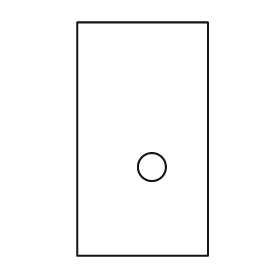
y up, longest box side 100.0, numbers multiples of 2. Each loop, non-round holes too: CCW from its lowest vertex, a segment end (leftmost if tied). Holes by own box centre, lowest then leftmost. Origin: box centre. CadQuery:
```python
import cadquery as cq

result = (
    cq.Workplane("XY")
    .moveTo(-28.0, -50.0)
    .lineTo(28.0, -50.0)
    .lineTo(28.0, 50.0)
    .lineTo(-28.0, 50.0)
    .close()
    .moveTo(4.0, -12.0)
    .circle(6.0)
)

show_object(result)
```